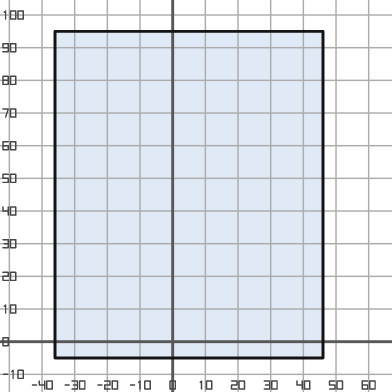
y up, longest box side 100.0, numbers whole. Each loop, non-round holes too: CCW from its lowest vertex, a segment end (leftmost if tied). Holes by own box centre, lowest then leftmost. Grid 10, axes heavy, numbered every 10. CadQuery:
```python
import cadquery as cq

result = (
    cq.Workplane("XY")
    .moveTo(-36.0, -5.0)
    .lineTo(46.0, -5.0)
    .lineTo(46.0, 95.0)
    .lineTo(-36.0, 95.0)
    .close()
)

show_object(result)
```